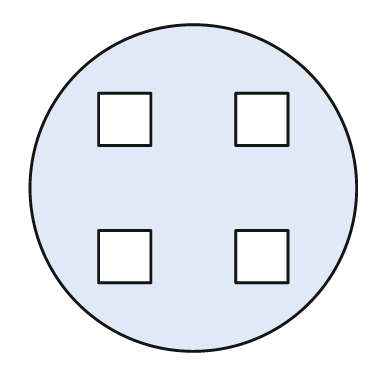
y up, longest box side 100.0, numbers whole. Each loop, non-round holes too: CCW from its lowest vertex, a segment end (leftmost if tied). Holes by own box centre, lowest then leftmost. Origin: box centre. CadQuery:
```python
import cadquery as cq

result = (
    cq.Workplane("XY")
    .moveTo(0.0, 0.0)
    .circle(50.0)
    .moveTo(-29.0, -29.0)
    .lineTo(-13.0, -29.0)
    .lineTo(-13.0, -13.0)
    .lineTo(-29.0, -13.0)
    .close()
    .moveTo(13.0, -29.0)
    .lineTo(29.0, -29.0)
    .lineTo(29.0, -13.0)
    .lineTo(13.0, -13.0)
    .close()
    .moveTo(-29.0, 13.0)
    .lineTo(-13.0, 13.0)
    .lineTo(-13.0, 29.0)
    .lineTo(-29.0, 29.0)
    .close()
    .moveTo(13.0, 13.0)
    .lineTo(29.0, 13.0)
    .lineTo(29.0, 29.0)
    .lineTo(13.0, 29.0)
    .close()
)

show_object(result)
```